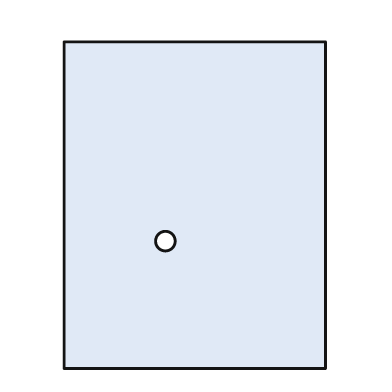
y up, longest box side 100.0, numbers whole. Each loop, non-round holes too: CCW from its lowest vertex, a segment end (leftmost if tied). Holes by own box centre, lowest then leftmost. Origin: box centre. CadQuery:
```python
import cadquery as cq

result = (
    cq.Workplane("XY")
    .moveTo(-40.0, -50.0)
    .lineTo(40.0, -50.0)
    .lineTo(40.0, 50.0)
    .lineTo(-40.0, 50.0)
    .close()
    .moveTo(-9.0, -11.0)
    .circle(3.0)
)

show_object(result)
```